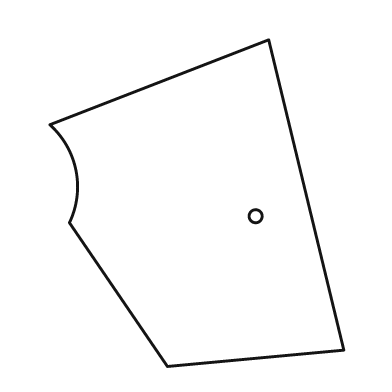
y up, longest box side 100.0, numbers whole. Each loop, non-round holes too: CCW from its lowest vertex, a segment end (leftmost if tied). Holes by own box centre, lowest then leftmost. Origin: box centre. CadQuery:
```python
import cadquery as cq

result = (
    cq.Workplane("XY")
    .moveTo(-9.0, -50.0)
    .lineTo(45.0, -45.0)
    .lineTo(22.0, 50.0)
    .lineTo(-45.0, 24.0)
    .threePointArc((-37.0, 10.0), (-39.0, -6.0))
    .close()
    .moveTo(18.0, -4.0)
    .circle(2.0)
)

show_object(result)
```